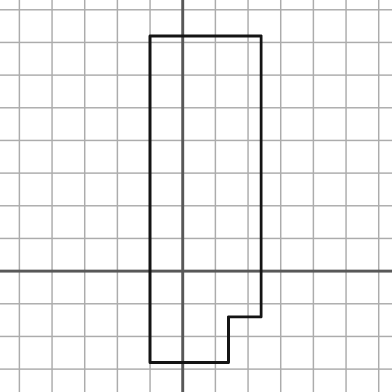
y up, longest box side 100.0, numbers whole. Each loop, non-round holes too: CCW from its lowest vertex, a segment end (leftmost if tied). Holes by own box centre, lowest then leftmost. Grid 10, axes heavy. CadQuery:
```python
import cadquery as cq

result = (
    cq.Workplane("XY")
    .moveTo(-10.0, -28.0)
    .lineTo(14.0, -28.0)
    .lineTo(14.0, -14.0)
    .lineTo(24.0, -14.0)
    .lineTo(24.0, 72.0)
    .lineTo(-10.0, 72.0)
    .close()
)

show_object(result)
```